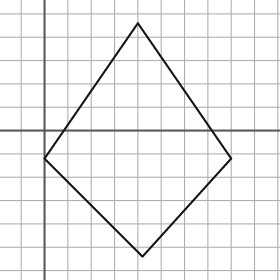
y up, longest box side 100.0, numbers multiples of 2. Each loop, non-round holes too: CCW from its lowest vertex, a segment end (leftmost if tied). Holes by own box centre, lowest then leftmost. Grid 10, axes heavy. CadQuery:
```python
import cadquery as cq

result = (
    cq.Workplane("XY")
    .moveTo(42.0, -54.0)
    .lineTo(80.0, -12.0)
    .lineTo(40.0, 46.0)
    .lineTo(0.0, -12.0)
    .close()
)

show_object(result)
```